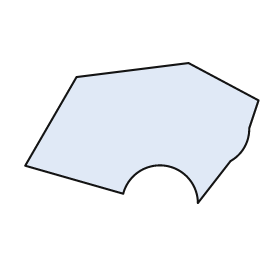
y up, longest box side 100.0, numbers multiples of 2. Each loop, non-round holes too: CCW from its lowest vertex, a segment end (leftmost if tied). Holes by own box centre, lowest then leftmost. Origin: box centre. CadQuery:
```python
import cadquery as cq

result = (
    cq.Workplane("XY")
    .moveTo(24.0, -30.0)
    .lineTo(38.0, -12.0)
    .threePointArc((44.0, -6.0), (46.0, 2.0))
    .lineTo(50.0, 14.0)
    .lineTo(20.0, 30.0)
    .lineTo(-28.0, 24.0)
    .lineTo(-50.0, -14.0)
    .lineTo(-8.0, -26.0)
    .threePointArc((10.0, -14.0), (24.0, -30.0))
    .close()
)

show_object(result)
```